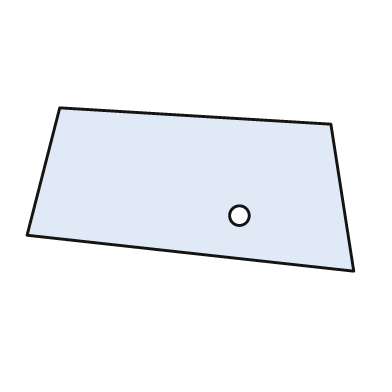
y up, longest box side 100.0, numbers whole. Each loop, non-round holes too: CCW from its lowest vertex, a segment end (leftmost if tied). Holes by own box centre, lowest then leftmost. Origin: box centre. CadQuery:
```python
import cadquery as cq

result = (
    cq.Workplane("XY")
    .moveTo(50.0, -25.0)
    .lineTo(43.0, 20.0)
    .lineTo(-40.0, 25.0)
    .lineTo(-50.0, -14.0)
    .close()
    .moveTo(15.0, -8.0)
    .circle(3.0)
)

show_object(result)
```